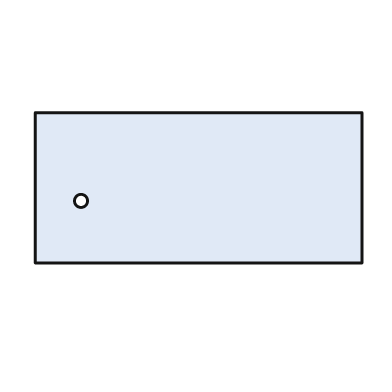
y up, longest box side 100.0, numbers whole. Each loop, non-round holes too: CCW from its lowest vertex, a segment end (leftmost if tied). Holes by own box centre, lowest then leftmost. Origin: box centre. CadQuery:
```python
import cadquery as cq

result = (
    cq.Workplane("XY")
    .moveTo(-50.0, -23.0)
    .lineTo(50.0, -23.0)
    .lineTo(50.0, 23.0)
    .lineTo(-50.0, 23.0)
    .close()
    .moveTo(-36.0, -4.0)
    .circle(2.0)
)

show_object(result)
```